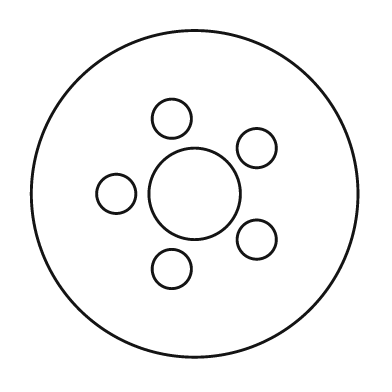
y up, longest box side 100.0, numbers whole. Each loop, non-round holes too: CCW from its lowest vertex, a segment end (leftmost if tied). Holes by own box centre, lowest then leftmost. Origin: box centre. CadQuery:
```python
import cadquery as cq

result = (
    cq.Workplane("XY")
    .moveTo(0.0, 0.0)
    .circle(50.0)
    .moveTo(-7.0, -23.0)
    .circle(6.0)
    .moveTo(19.0, -14.0)
    .circle(6.0)
    .moveTo(-24.0, 0.0)
    .circle(6.0)
    .moveTo(0.0, 0.0)
    .circle(14.0)
    .moveTo(19.0, 14.0)
    .circle(6.0)
    .moveTo(-7.0, 23.0)
    .circle(6.0)
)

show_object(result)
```